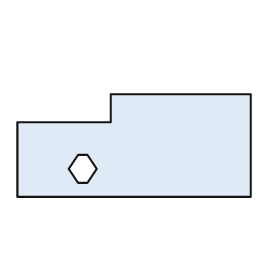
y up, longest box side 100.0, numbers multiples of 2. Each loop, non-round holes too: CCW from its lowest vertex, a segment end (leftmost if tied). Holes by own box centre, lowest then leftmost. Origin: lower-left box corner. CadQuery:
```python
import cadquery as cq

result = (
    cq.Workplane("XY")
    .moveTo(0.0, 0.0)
    .lineTo(100.0, 0.0)
    .lineTo(100.0, 44.0)
    .lineTo(40.0, 44.0)
    .lineTo(40.0, 32.0)
    .lineTo(0.0, 32.0)
    .close()
    .moveTo(26.0, 6.0)
    .lineTo(30.0, 6.0)
    .lineTo(34.0, 12.0)
    .lineTo(30.0, 18.0)
    .lineTo(26.0, 18.0)
    .lineTo(22.0, 12.0)
    .close()
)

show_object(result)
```